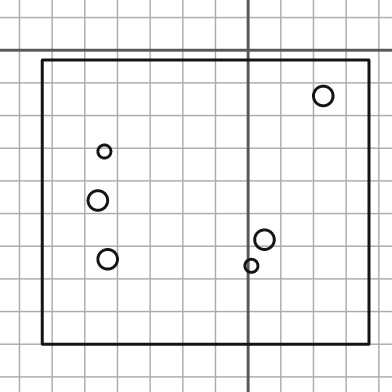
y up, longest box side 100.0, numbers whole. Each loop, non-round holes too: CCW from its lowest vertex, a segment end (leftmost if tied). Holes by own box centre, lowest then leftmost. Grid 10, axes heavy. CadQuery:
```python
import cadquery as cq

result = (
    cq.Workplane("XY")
    .moveTo(-63.0, -90.0)
    .lineTo(37.0, -90.0)
    .lineTo(37.0, -3.0)
    .lineTo(-63.0, -3.0)
    .close()
    .moveTo(1.0, -66.0)
    .circle(2.0)
    .moveTo(-43.0, -64.0)
    .circle(3.0)
    .moveTo(5.0, -58.0)
    .circle(3.0)
    .moveTo(-46.0, -46.0)
    .circle(3.0)
    .moveTo(-44.0, -31.0)
    .circle(2.0)
    .moveTo(23.0, -14.0)
    .circle(3.0)
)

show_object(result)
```